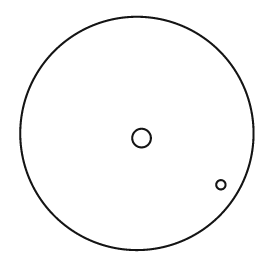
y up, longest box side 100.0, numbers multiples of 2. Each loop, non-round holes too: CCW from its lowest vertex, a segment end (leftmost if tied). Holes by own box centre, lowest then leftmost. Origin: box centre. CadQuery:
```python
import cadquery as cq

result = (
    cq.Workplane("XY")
    .moveTo(0.0, 0.0)
    .circle(50.0)
    .moveTo(36.0, -22.0)
    .circle(2.0)
    .moveTo(2.0, -2.0)
    .circle(4.0)
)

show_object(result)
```